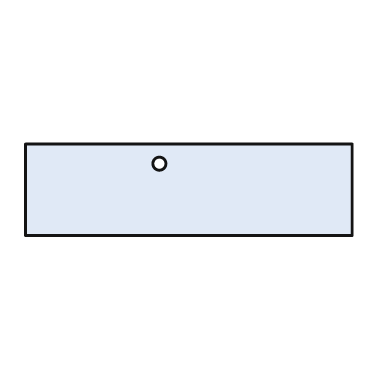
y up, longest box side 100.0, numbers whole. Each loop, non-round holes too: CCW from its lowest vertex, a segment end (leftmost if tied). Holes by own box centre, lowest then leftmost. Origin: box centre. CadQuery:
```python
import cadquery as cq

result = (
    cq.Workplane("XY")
    .moveTo(-50.0, -14.0)
    .lineTo(50.0, -14.0)
    .lineTo(50.0, 14.0)
    .lineTo(-50.0, 14.0)
    .close()
    .moveTo(-9.0, 8.0)
    .circle(2.0)
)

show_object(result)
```